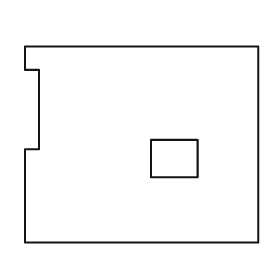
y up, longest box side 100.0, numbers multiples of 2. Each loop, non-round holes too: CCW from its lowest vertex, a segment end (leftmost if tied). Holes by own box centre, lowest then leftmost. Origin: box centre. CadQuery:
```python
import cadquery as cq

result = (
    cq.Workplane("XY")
    .moveTo(-50.0, -42.0)
    .lineTo(50.0, -42.0)
    .lineTo(50.0, 42.0)
    .lineTo(-50.0, 42.0)
    .lineTo(-50.0, 32.0)
    .lineTo(-44.0, 32.0)
    .lineTo(-44.0, -2.0)
    .lineTo(-50.0, -2.0)
    .close()
    .moveTo(4.0, -14.0)
    .lineTo(24.0, -14.0)
    .lineTo(24.0, 2.0)
    .lineTo(4.0, 2.0)
    .close()
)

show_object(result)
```